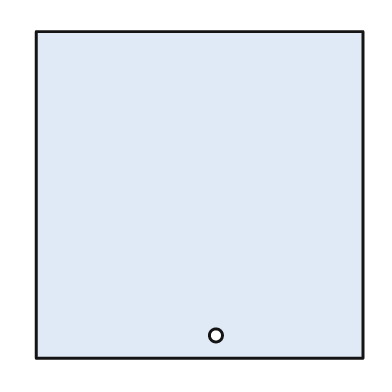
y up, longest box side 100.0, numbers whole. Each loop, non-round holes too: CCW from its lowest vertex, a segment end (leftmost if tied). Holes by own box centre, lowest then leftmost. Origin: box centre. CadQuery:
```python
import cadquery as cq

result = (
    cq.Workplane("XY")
    .moveTo(-50.0, -50.0)
    .lineTo(50.0, -50.0)
    .lineTo(50.0, 50.0)
    .lineTo(-50.0, 50.0)
    .close()
    .moveTo(5.0, -43.0)
    .circle(2.0)
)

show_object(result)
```